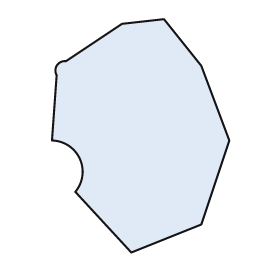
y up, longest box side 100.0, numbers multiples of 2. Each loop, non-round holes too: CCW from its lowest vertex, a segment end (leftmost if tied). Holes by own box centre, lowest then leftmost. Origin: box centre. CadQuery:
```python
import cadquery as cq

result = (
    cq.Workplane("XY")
    .moveTo(-4.0, -50.0)
    .lineTo(26.0, -38.0)
    .lineTo(38.0, -2.0)
    .lineTo(26.0, 30.0)
    .lineTo(10.0, 50.0)
    .lineTo(-8.0, 48.0)
    .lineTo(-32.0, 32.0)
    .threePointArc((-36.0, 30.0), (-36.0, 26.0))
    .lineTo(-38.0, -2.0)
    .threePointArc((-26.0, -10.0), (-28.0, -24.0))
    .close()
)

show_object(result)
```